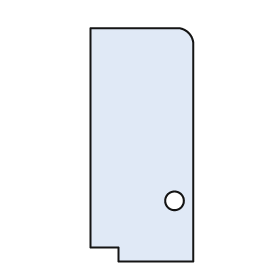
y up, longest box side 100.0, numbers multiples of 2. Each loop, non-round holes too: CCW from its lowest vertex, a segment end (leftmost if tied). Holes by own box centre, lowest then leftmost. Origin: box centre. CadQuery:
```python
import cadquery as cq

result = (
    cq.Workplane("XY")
    .moveTo(-10.0, -50.0)
    .lineTo(22.0, -50.0)
    .lineTo(22.0, 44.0)
    .threePointArc((20.0, 48.0), (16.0, 50.0))
    .lineTo(-22.0, 50.0)
    .lineTo(-22.0, -44.0)
    .lineTo(-10.0, -44.0)
    .close()
    .moveTo(14.0, -24.0)
    .circle(4.0)
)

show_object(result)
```